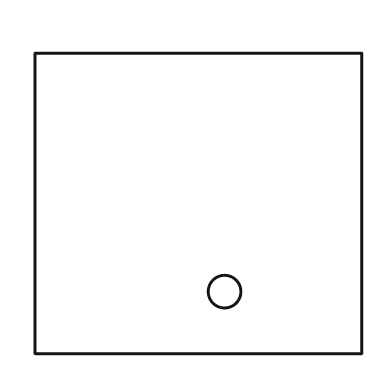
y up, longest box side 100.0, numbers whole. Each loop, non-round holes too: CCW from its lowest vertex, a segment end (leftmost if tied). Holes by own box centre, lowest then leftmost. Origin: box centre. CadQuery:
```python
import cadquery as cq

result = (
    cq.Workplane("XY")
    .moveTo(-50.0, -46.0)
    .lineTo(50.0, -46.0)
    .lineTo(50.0, 46.0)
    .lineTo(-50.0, 46.0)
    .close()
    .moveTo(8.0, -27.0)
    .circle(5.0)
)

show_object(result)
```